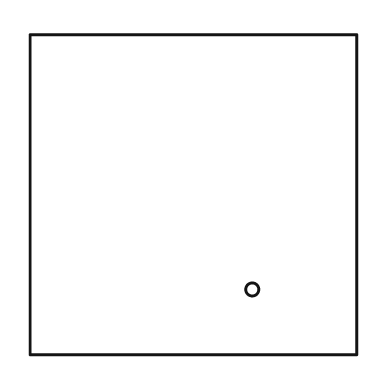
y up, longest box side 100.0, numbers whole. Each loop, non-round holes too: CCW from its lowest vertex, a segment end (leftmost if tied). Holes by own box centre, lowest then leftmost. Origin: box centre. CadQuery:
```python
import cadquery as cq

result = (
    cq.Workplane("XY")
    .moveTo(-50.0, -49.0)
    .lineTo(50.0, -49.0)
    .lineTo(50.0, 49.0)
    .lineTo(-50.0, 49.0)
    .close()
    .moveTo(18.0, -29.0)
    .circle(2.0)
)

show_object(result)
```